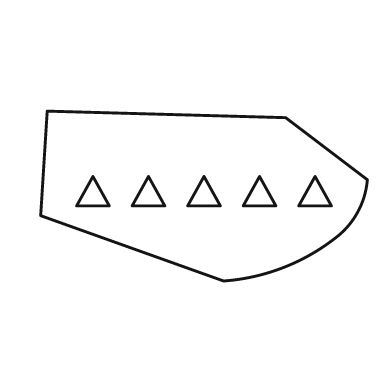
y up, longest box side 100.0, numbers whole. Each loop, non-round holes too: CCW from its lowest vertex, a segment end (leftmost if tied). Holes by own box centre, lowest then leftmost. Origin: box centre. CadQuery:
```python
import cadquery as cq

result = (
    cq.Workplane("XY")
    .moveTo(6.0, -26.0)
    .threePointArc((24.0, -22.0), (40.0, -13.0))
    .threePointArc((47.0, -5.0), (50.0, 5.0))
    .lineTo(25.0, 24.0)
    .lineTo(-48.0, 26.0)
    .lineTo(-50.0, -6.0)
    .close()
    .moveTo(-39.0, -3.0)
    .lineTo(-29.0, -3.0)
    .lineTo(-34.0, 6.0)
    .close()
    .moveTo(-22.0, -3.0)
    .lineTo(-12.0, -3.0)
    .lineTo(-17.0, 6.0)
    .close()
    .moveTo(-5.0, -3.0)
    .lineTo(5.0, -3.0)
    .lineTo(0.0, 6.0)
    .close()
    .moveTo(12.0, -3.0)
    .lineTo(22.0, -3.0)
    .lineTo(17.0, 6.0)
    .close()
    .moveTo(29.0, -3.0)
    .lineTo(39.0, -3.0)
    .lineTo(34.0, 6.0)
    .close()
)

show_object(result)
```